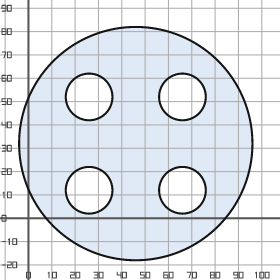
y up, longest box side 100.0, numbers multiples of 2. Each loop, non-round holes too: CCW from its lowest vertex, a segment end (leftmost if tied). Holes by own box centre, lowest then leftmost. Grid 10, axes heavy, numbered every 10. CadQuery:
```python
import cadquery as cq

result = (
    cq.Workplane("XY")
    .moveTo(46.0, 32.0)
    .circle(50.0)
    .moveTo(26.0, 12.0)
    .circle(10.0)
    .moveTo(66.0, 12.0)
    .circle(10.0)
    .moveTo(26.0, 52.0)
    .circle(10.0)
    .moveTo(66.0, 52.0)
    .circle(10.0)
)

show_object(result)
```